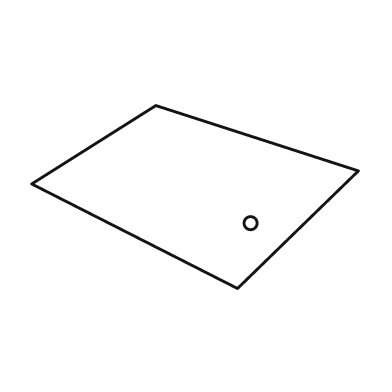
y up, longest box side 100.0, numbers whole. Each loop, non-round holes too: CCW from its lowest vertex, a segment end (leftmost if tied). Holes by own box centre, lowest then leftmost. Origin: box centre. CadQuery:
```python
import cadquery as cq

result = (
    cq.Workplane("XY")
    .moveTo(13.0, -28.0)
    .lineTo(50.0, 8.0)
    .lineTo(-12.0, 28.0)
    .lineTo(-50.0, 4.0)
    .close()
    .moveTo(17.0, -8.0)
    .circle(2.0)
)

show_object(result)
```